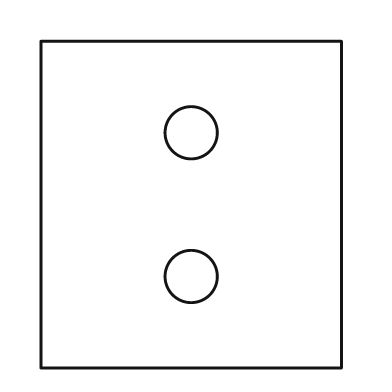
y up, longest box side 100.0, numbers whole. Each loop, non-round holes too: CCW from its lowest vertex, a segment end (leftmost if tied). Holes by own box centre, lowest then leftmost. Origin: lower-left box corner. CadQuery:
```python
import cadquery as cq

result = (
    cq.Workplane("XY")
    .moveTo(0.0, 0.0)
    .lineTo(92.0, 0.0)
    .lineTo(92.0, 100.0)
    .lineTo(0.0, 100.0)
    .close()
    .moveTo(46.0, 28.0)
    .circle(8.0)
    .moveTo(46.0, 72.0)
    .circle(8.0)
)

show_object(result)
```